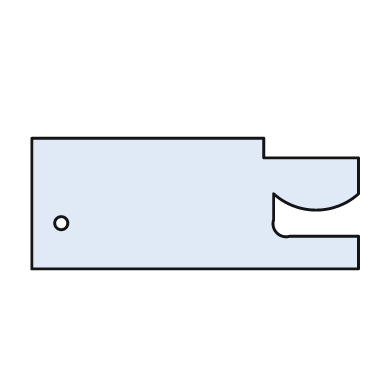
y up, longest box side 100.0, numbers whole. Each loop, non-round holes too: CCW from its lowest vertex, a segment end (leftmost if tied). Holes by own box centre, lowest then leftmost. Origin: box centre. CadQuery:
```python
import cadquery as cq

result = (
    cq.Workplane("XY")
    .moveTo(-50.0, -20.0)
    .lineTo(50.0, -20.0)
    .lineTo(50.0, -10.0)
    .lineTo(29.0, -10.0)
    .threePointArc((25.0, -9.0), (24.0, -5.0))
    .lineTo(24.0, 3.0)
    .threePointArc((37.0, -2.0), (50.0, 3.0))
    .lineTo(50.0, 14.0)
    .lineTo(21.0, 14.0)
    .lineTo(21.0, 20.0)
    .lineTo(-50.0, 20.0)
    .close()
    .moveTo(-41.0, -6.0)
    .circle(2.0)
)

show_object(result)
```